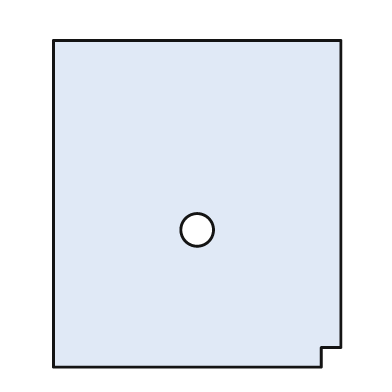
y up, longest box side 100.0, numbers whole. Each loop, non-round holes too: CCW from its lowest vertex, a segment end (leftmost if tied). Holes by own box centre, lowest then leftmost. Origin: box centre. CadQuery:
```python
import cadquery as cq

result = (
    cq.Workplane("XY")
    .moveTo(-44.0, -50.0)
    .lineTo(38.0, -50.0)
    .lineTo(38.0, -44.0)
    .lineTo(44.0, -44.0)
    .lineTo(44.0, 50.0)
    .lineTo(-44.0, 50.0)
    .close()
    .moveTo(0.0, -8.0)
    .circle(5.0)
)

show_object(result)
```